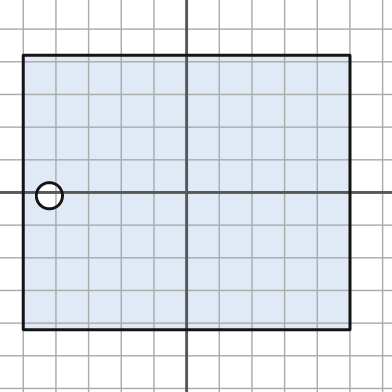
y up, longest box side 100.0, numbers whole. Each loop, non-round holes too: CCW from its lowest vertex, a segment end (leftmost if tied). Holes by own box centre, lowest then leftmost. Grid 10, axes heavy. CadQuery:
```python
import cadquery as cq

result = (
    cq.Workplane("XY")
    .moveTo(-50.0, -42.0)
    .lineTo(50.0, -42.0)
    .lineTo(50.0, 42.0)
    .lineTo(-50.0, 42.0)
    .close()
    .moveTo(-42.0, -1.0)
    .circle(4.0)
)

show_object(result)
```